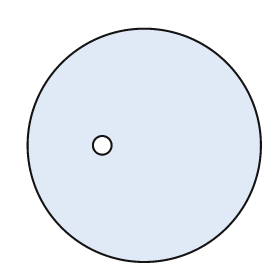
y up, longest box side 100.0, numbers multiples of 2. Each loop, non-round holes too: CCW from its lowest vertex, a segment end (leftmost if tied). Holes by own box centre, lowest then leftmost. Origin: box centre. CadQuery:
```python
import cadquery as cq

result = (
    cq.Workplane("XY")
    .moveTo(0.0, 0.0)
    .circle(50.0)
    .moveTo(-18.0, 0.0)
    .circle(4.0)
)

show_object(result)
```